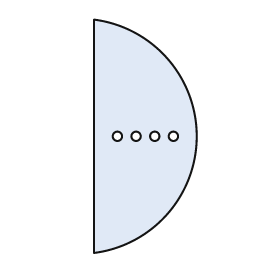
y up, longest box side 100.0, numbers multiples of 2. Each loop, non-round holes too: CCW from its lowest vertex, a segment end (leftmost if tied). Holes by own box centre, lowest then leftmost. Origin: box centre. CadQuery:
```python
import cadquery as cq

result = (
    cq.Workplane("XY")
    .moveTo(-22.0, -50.0)
    .threePointArc((22.0, 0.0), (-22.0, 50.0))
    .close()
    .moveTo(-12.0, 0.0)
    .circle(2.0)
    .moveTo(-4.0, 0.0)
    .circle(2.0)
    .moveTo(4.0, 0.0)
    .circle(2.0)
    .moveTo(12.0, 0.0)
    .circle(2.0)
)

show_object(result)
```